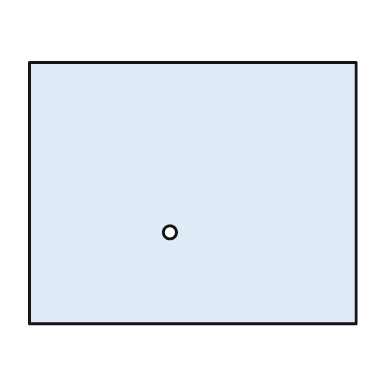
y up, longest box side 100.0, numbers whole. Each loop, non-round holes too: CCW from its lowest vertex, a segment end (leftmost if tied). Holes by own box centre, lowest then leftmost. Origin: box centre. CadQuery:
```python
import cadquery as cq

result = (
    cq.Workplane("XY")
    .moveTo(-50.0, -40.0)
    .lineTo(50.0, -40.0)
    .lineTo(50.0, 40.0)
    .lineTo(-50.0, 40.0)
    .close()
    .moveTo(-7.0, -12.0)
    .circle(2.0)
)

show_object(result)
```